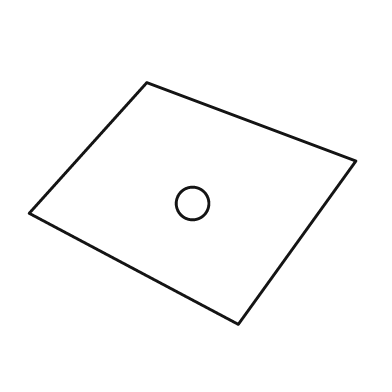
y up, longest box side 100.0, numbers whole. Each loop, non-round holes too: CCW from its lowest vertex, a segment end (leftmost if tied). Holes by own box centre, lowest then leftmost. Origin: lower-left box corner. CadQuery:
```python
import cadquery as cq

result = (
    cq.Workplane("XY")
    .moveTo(64.0, 0.0)
    .lineTo(100.0, 50.0)
    .lineTo(36.0, 74.0)
    .lineTo(0.0, 34.0)
    .close()
    .moveTo(50.0, 37.0)
    .circle(5.0)
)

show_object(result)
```